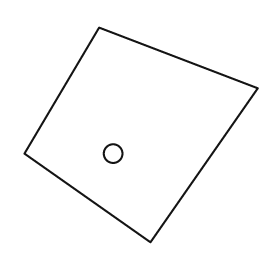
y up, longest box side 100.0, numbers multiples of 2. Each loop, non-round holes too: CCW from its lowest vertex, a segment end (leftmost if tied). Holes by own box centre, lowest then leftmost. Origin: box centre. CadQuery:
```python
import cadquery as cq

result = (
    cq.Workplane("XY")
    .moveTo(4.0, -46.0)
    .lineTo(50.0, 20.0)
    .lineTo(-18.0, 46.0)
    .lineTo(-50.0, -8.0)
    .close()
    .moveTo(-12.0, -8.0)
    .circle(4.0)
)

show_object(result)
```